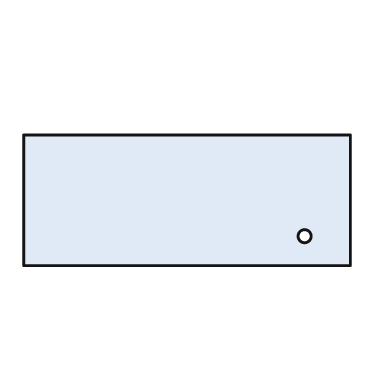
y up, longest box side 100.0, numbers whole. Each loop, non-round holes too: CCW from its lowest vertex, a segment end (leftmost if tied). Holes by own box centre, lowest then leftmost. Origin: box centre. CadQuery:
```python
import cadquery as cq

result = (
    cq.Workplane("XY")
    .moveTo(-50.0, -20.0)
    .lineTo(50.0, -20.0)
    .lineTo(50.0, 20.0)
    .lineTo(-50.0, 20.0)
    .close()
    .moveTo(36.0, -11.0)
    .circle(2.0)
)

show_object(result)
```